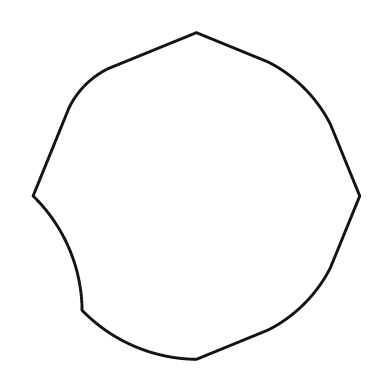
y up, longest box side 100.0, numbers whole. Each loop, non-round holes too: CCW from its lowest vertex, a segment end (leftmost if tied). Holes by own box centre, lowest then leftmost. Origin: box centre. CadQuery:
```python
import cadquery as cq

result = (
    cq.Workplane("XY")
    .moveTo(0.0, -50.0)
    .lineTo(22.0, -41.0)
    .threePointArc((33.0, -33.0), (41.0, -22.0))
    .lineTo(50.0, 0.0)
    .lineTo(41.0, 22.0)
    .threePointArc((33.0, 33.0), (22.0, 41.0))
    .lineTo(0.0, 50.0)
    .lineTo(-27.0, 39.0)
    .threePointArc((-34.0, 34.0), (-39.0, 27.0))
    .lineTo(-50.0, 0.0)
    .threePointArc((-39.0, -16.0), (-35.0, -35.0))
    .threePointArc((-19.0, -46.0), (0.0, -50.0))
    .close()
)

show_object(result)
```